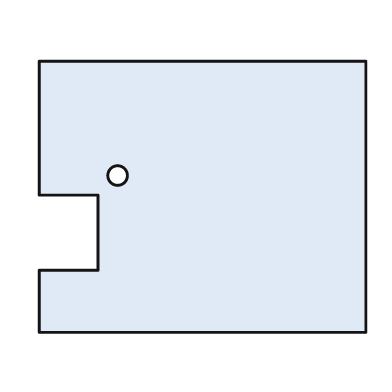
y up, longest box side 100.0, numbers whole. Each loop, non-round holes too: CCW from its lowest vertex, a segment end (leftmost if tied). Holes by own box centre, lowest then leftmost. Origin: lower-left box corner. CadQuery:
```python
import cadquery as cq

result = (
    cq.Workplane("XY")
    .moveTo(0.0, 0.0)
    .lineTo(100.0, 0.0)
    .lineTo(100.0, 83.0)
    .lineTo(0.0, 83.0)
    .lineTo(0.0, 42.0)
    .lineTo(18.0, 42.0)
    .lineTo(18.0, 19.0)
    .lineTo(0.0, 19.0)
    .close()
    .moveTo(24.0, 48.0)
    .circle(3.0)
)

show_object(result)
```